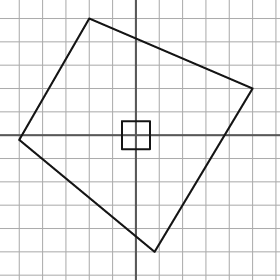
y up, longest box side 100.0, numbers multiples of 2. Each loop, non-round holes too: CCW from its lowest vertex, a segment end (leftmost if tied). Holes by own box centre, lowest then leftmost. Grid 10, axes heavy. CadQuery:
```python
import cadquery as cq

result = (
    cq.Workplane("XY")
    .moveTo(8.0, -50.0)
    .lineTo(50.0, 20.0)
    .lineTo(-20.0, 50.0)
    .lineTo(-50.0, -2.0)
    .close()
    .moveTo(-6.0, -6.0)
    .lineTo(6.0, -6.0)
    .lineTo(6.0, 6.0)
    .lineTo(-6.0, 6.0)
    .close()
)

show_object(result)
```